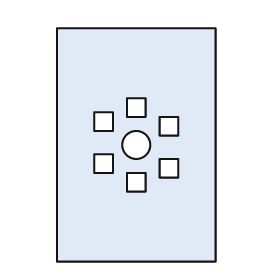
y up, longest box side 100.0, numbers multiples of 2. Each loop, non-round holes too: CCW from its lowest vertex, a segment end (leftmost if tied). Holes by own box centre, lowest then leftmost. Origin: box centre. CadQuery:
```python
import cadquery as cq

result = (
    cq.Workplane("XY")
    .moveTo(-34.0, -50.0)
    .lineTo(34.0, -50.0)
    .lineTo(34.0, 50.0)
    .lineTo(-34.0, 50.0)
    .close()
    .moveTo(-4.0, -20.0)
    .lineTo(4.0, -20.0)
    .lineTo(4.0, -12.0)
    .lineTo(-4.0, -12.0)
    .close()
    .moveTo(10.0, -14.0)
    .lineTo(18.0, -14.0)
    .lineTo(18.0, -6.0)
    .lineTo(10.0, -6.0)
    .close()
    .moveTo(-18.0, -12.0)
    .lineTo(-10.0, -12.0)
    .lineTo(-10.0, -4.0)
    .lineTo(-18.0, -4.0)
    .close()
    .moveTo(0.0, 0.0)
    .circle(6.0)
    .moveTo(10.0, 4.0)
    .lineTo(18.0, 4.0)
    .lineTo(18.0, 12.0)
    .lineTo(10.0, 12.0)
    .close()
    .moveTo(-18.0, 6.0)
    .lineTo(-10.0, 6.0)
    .lineTo(-10.0, 14.0)
    .lineTo(-18.0, 14.0)
    .close()
    .moveTo(-4.0, 12.0)
    .lineTo(4.0, 12.0)
    .lineTo(4.0, 20.0)
    .lineTo(-4.0, 20.0)
    .close()
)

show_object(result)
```